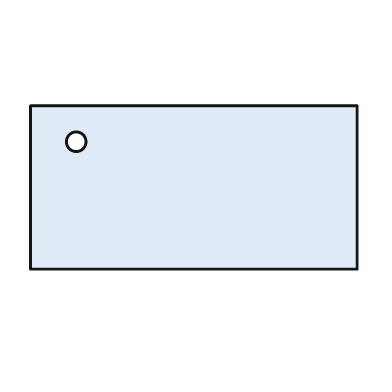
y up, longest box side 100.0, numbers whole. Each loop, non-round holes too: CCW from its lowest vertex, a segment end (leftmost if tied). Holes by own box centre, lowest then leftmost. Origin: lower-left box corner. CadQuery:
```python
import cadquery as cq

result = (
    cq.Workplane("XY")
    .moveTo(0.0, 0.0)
    .lineTo(100.0, 0.0)
    .lineTo(100.0, 50.0)
    .lineTo(0.0, 50.0)
    .close()
    .moveTo(14.0, 39.0)
    .circle(3.0)
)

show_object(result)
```